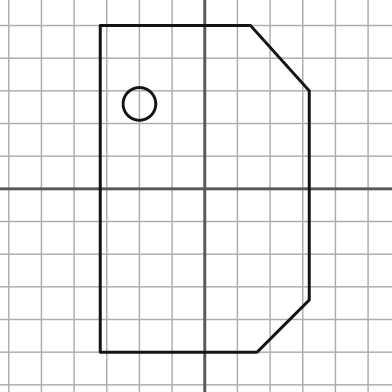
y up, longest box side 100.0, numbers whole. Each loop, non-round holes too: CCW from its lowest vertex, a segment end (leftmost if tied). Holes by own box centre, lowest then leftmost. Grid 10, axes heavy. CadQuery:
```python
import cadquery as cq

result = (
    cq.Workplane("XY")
    .moveTo(-32.0, -50.0)
    .lineTo(16.0, -50.0)
    .lineTo(32.0, -34.0)
    .lineTo(32.0, 30.0)
    .lineTo(14.0, 50.0)
    .lineTo(-32.0, 50.0)
    .close()
    .moveTo(-20.0, 26.0)
    .circle(5.0)
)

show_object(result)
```